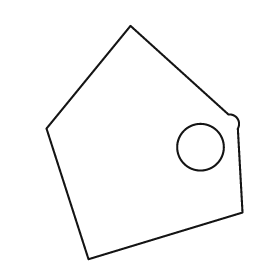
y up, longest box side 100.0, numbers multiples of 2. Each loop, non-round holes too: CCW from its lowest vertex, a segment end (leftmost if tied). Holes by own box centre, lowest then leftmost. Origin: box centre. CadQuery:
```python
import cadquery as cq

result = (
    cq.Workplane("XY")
    .moveTo(-24.0, -50.0)
    .lineTo(42.0, -30.0)
    .lineTo(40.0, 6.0)
    .threePointArc((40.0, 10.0), (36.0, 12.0))
    .lineTo(-6.0, 50.0)
    .lineTo(-42.0, 6.0)
    .close()
    .moveTo(24.0, -2.0)
    .circle(10.0)
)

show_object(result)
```